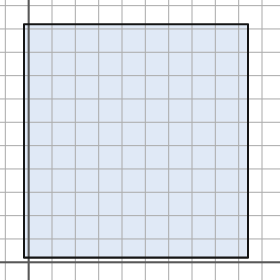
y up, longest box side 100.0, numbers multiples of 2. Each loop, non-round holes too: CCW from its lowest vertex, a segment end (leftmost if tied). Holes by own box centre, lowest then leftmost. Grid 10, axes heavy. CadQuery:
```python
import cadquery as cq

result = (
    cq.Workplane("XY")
    .moveTo(-2.0, 2.0)
    .lineTo(94.0, 2.0)
    .lineTo(94.0, 102.0)
    .lineTo(-2.0, 102.0)
    .close()
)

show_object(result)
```